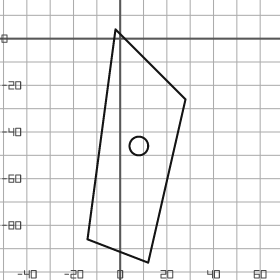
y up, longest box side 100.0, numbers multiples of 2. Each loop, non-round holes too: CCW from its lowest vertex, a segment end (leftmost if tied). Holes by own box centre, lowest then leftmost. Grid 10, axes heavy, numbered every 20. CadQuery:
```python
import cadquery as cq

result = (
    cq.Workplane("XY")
    .moveTo(12.0, -96.0)
    .lineTo(28.0, -26.0)
    .lineTo(-2.0, 4.0)
    .lineTo(-14.0, -86.0)
    .close()
    .moveTo(8.0, -46.0)
    .circle(4.0)
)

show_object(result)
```